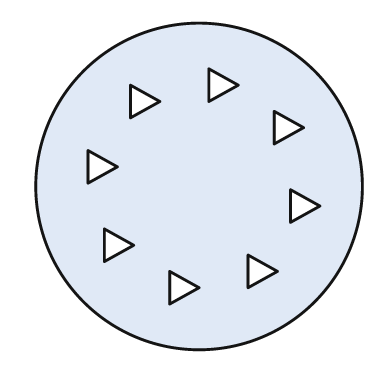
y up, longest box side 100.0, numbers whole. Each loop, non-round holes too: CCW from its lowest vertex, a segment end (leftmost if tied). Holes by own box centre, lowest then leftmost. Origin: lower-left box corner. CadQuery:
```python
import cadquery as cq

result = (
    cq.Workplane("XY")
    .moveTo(50.0, 50.0)
    .circle(50.0)
    .moveTo(41.0, 14.0)
    .lineTo(50.0, 19.0)
    .lineTo(41.0, 24.0)
    .close()
    .moveTo(65.0, 19.0)
    .lineTo(74.0, 24.0)
    .lineTo(65.0, 29.0)
    .close()
    .moveTo(21.0, 27.0)
    .lineTo(30.0, 32.0)
    .lineTo(21.0, 37.0)
    .close()
    .moveTo(78.0, 39.0)
    .lineTo(87.0, 44.0)
    .lineTo(78.0, 49.0)
    .close()
    .moveTo(16.0, 51.0)
    .lineTo(25.0, 56.0)
    .lineTo(16.0, 61.0)
    .close()
    .moveTo(73.0, 63.0)
    .lineTo(82.0, 68.0)
    .lineTo(73.0, 73.0)
    .close()
    .moveTo(29.0, 71.0)
    .lineTo(38.0, 76.0)
    .lineTo(29.0, 81.0)
    .close()
    .moveTo(53.0, 76.0)
    .lineTo(62.0, 81.0)
    .lineTo(53.0, 86.0)
    .close()
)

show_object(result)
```